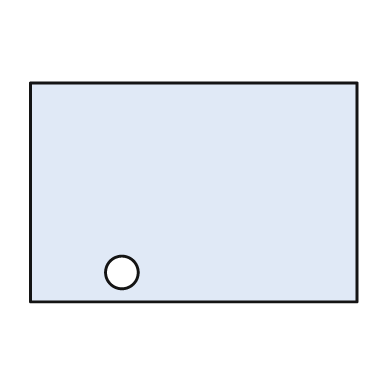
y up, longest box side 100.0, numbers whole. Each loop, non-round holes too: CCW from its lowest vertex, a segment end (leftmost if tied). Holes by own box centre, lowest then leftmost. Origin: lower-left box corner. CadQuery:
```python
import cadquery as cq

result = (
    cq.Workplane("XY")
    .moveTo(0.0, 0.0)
    .lineTo(100.0, 0.0)
    .lineTo(100.0, 67.0)
    .lineTo(0.0, 67.0)
    .close()
    .moveTo(28.0, 9.0)
    .circle(5.0)
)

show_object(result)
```